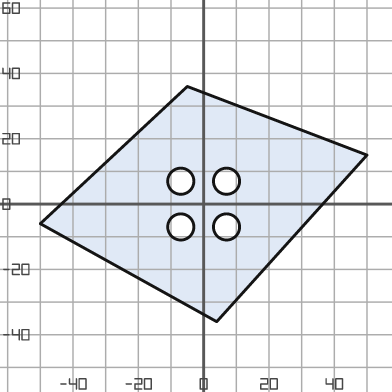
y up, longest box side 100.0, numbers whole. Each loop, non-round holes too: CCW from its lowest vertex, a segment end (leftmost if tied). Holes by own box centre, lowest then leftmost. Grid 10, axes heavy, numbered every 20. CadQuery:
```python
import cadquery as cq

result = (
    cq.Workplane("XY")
    .moveTo(4.0, -36.0)
    .lineTo(50.0, 15.0)
    .lineTo(-5.0, 36.0)
    .lineTo(-50.0, -6.0)
    .close()
    .moveTo(-7.0, -7.0)
    .circle(4.0)
    .moveTo(7.0, -7.0)
    .circle(4.0)
    .moveTo(-7.0, 7.0)
    .circle(4.0)
    .moveTo(7.0, 7.0)
    .circle(4.0)
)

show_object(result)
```